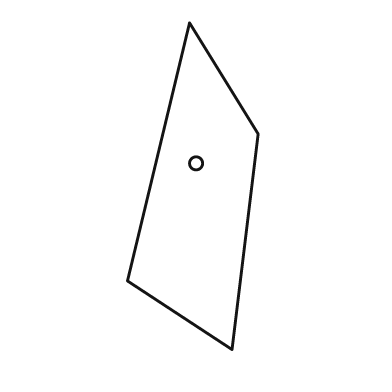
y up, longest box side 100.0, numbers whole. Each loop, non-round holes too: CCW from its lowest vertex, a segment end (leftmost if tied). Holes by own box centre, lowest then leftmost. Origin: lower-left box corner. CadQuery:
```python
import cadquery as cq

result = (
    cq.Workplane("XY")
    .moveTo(32.0, 0.0)
    .lineTo(40.0, 66.0)
    .lineTo(19.0, 100.0)
    .lineTo(0.0, 21.0)
    .close()
    .moveTo(21.0, 57.0)
    .circle(2.0)
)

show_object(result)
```